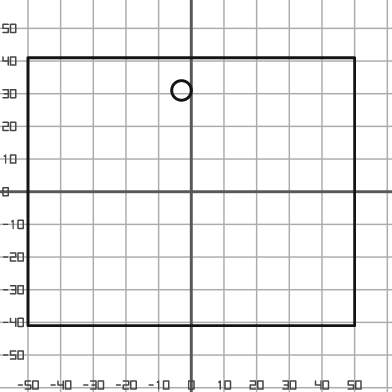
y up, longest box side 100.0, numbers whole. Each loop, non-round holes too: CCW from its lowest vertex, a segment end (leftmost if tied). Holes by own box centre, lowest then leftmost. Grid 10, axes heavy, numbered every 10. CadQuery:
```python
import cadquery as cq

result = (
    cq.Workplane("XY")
    .moveTo(-50.0, -41.0)
    .lineTo(50.0, -41.0)
    .lineTo(50.0, 41.0)
    .lineTo(-50.0, 41.0)
    .close()
    .moveTo(-3.0, 31.0)
    .circle(3.0)
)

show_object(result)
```